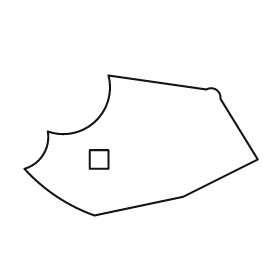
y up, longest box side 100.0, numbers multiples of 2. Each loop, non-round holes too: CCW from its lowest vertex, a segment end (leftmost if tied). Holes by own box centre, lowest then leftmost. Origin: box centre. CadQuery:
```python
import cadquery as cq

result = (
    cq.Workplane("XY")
    .moveTo(-20.0, -30.0)
    .lineTo(18.0, -22.0)
    .lineTo(50.0, -6.0)
    .lineTo(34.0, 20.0)
    .threePointArc((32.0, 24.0), (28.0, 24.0))
    .lineTo(-14.0, 30.0)
    .threePointArc((-20.0, 10.0), (-40.0, 6.0))
    .threePointArc((-42.0, -4.0), (-50.0, -10.0))
    .threePointArc((-36.0, -22.0), (-20.0, -30.0))
    .close()
    .moveTo(-22.0, -10.0)
    .lineTo(-14.0, -10.0)
    .lineTo(-14.0, -2.0)
    .lineTo(-22.0, -2.0)
    .close()
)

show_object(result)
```